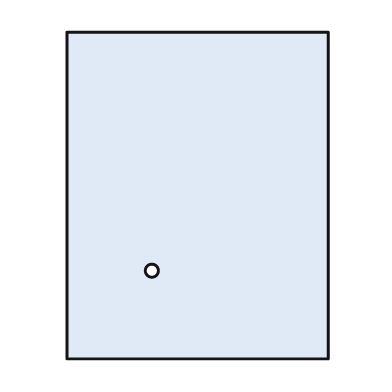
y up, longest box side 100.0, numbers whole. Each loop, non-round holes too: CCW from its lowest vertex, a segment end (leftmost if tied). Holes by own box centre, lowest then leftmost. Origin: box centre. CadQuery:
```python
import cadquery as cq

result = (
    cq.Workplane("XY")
    .moveTo(-40.0, -50.0)
    .lineTo(40.0, -50.0)
    .lineTo(40.0, 50.0)
    .lineTo(-40.0, 50.0)
    .close()
    .moveTo(-14.0, -23.0)
    .circle(2.0)
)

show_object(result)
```